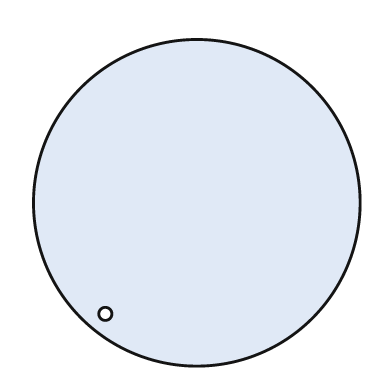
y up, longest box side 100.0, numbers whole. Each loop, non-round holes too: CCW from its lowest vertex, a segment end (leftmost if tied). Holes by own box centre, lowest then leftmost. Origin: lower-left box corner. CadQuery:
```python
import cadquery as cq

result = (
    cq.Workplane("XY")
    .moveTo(50.0, 50.0)
    .circle(50.0)
    .moveTo(22.0, 16.0)
    .circle(2.0)
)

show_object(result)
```